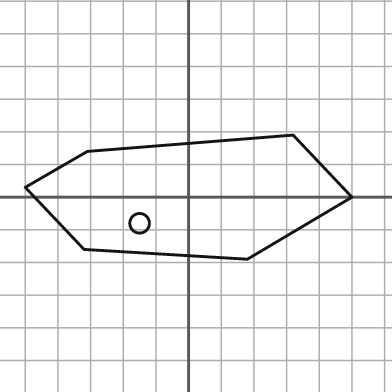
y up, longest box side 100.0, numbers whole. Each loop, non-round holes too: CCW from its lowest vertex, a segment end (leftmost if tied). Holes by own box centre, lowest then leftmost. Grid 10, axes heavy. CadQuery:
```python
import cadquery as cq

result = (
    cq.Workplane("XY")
    .moveTo(18.0, -19.0)
    .lineTo(50.0, 0.0)
    .lineTo(32.0, 19.0)
    .lineTo(-31.0, 14.0)
    .lineTo(-50.0, 3.0)
    .lineTo(-32.0, -16.0)
    .close()
    .moveTo(-15.0, -8.0)
    .circle(3.0)
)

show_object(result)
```